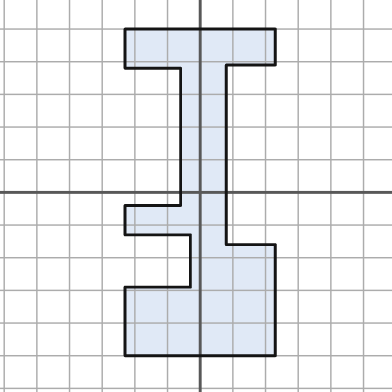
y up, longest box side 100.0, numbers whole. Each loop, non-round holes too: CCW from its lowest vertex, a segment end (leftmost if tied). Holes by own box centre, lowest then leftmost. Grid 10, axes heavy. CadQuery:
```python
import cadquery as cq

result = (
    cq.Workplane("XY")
    .moveTo(-23.0, -50.0)
    .lineTo(23.0, -50.0)
    .lineTo(23.0, -16.0)
    .lineTo(8.0, -16.0)
    .lineTo(8.0, 39.0)
    .lineTo(23.0, 39.0)
    .lineTo(23.0, 50.0)
    .lineTo(-23.0, 50.0)
    .lineTo(-23.0, 38.0)
    .lineTo(-6.0, 38.0)
    .lineTo(-6.0, -4.0)
    .lineTo(-23.0, -4.0)
    .lineTo(-23.0, -13.0)
    .lineTo(-3.0, -13.0)
    .lineTo(-3.0, -29.0)
    .lineTo(-23.0, -29.0)
    .close()
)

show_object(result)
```